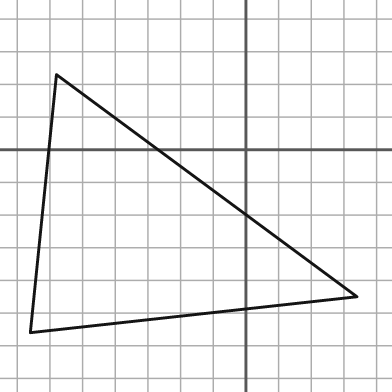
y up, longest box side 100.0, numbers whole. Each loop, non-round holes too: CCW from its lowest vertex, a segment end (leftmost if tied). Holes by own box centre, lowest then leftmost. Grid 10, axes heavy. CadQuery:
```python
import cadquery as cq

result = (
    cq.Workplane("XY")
    .moveTo(-66.0, -56.0)
    .lineTo(34.0, -45.0)
    .lineTo(-58.0, 23.0)
    .close()
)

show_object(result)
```